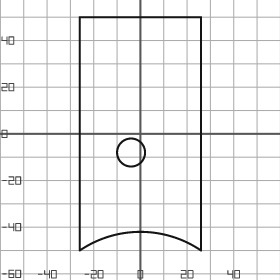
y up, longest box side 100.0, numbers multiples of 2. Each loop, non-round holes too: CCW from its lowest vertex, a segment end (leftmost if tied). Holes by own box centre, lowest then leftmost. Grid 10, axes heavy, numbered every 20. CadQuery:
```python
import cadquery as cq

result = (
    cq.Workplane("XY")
    .moveTo(-26.0, -50.0)
    .threePointArc((0.0, -42.0), (26.0, -50.0))
    .lineTo(26.0, 50.0)
    .lineTo(-26.0, 50.0)
    .close()
    .moveTo(-4.0, -8.0)
    .circle(6.0)
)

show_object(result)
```